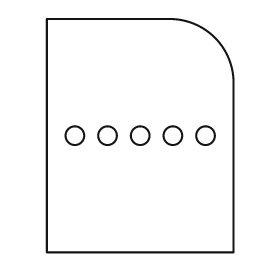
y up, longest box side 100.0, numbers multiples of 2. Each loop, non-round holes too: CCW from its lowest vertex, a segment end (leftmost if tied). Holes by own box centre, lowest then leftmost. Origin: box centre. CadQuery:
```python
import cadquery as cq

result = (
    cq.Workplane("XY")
    .moveTo(-40.0, -50.0)
    .lineTo(40.0, -50.0)
    .lineTo(40.0, 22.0)
    .threePointArc((32.0, 42.0), (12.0, 50.0))
    .lineTo(-40.0, 50.0)
    .close()
    .moveTo(-28.0, 0.0)
    .circle(4.0)
    .moveTo(-14.0, 0.0)
    .circle(4.0)
    .moveTo(0.0, 0.0)
    .circle(4.0)
    .moveTo(14.0, 0.0)
    .circle(4.0)
    .moveTo(28.0, 0.0)
    .circle(4.0)
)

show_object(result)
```